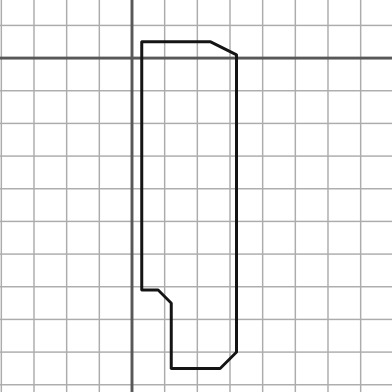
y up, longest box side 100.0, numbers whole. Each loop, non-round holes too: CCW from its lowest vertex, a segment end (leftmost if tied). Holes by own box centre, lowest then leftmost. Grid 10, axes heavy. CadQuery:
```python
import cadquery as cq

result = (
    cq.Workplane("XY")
    .moveTo(12.0, -95.0)
    .lineTo(27.0, -95.0)
    .lineTo(32.0, -90.0)
    .lineTo(32.0, 1.0)
    .lineTo(24.0, 5.0)
    .lineTo(3.0, 5.0)
    .lineTo(3.0, -71.0)
    .lineTo(8.0, -71.0)
    .lineTo(12.0, -75.0)
    .close()
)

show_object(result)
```